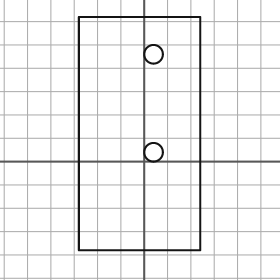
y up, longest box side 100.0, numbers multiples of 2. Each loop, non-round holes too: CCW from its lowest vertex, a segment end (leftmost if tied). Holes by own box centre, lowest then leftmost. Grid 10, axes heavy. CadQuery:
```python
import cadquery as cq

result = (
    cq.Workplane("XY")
    .moveTo(-28.0, -38.0)
    .lineTo(24.0, -38.0)
    .lineTo(24.0, 62.0)
    .lineTo(-28.0, 62.0)
    .close()
    .moveTo(4.0, 4.0)
    .circle(4.0)
    .moveTo(4.0, 46.0)
    .circle(4.0)
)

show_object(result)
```